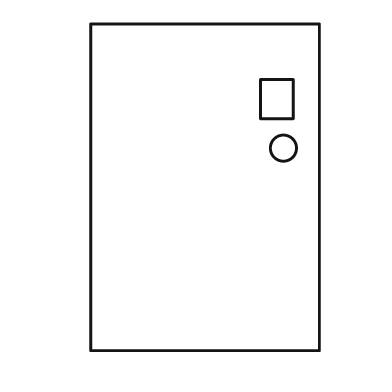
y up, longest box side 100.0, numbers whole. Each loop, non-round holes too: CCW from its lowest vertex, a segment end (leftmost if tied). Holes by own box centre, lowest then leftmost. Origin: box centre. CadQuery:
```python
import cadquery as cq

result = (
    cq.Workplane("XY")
    .moveTo(-35.0, -50.0)
    .lineTo(35.0, -50.0)
    .lineTo(35.0, 50.0)
    .lineTo(-35.0, 50.0)
    .close()
    .moveTo(24.0, 12.0)
    .circle(4.0)
    .moveTo(17.0, 21.0)
    .lineTo(27.0, 21.0)
    .lineTo(27.0, 33.0)
    .lineTo(17.0, 33.0)
    .close()
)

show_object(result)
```